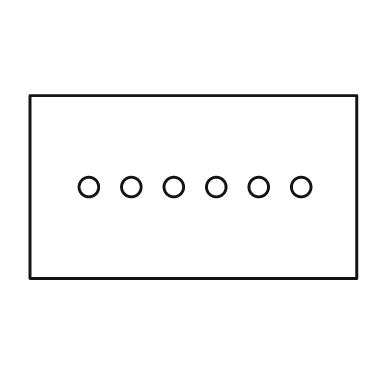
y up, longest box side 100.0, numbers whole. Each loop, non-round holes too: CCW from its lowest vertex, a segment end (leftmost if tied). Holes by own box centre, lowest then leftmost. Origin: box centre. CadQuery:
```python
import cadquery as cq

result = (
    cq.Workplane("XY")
    .moveTo(-50.0, -28.0)
    .lineTo(50.0, -28.0)
    .lineTo(50.0, 28.0)
    .lineTo(-50.0, 28.0)
    .close()
    .moveTo(-32.0, 0.0)
    .circle(3.0)
    .moveTo(-19.0, 0.0)
    .circle(3.0)
    .moveTo(-6.0, 0.0)
    .circle(3.0)
    .moveTo(7.0, 0.0)
    .circle(3.0)
    .moveTo(20.0, 0.0)
    .circle(3.0)
    .moveTo(33.0, 0.0)
    .circle(3.0)
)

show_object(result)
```